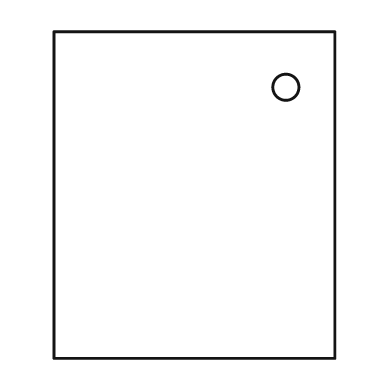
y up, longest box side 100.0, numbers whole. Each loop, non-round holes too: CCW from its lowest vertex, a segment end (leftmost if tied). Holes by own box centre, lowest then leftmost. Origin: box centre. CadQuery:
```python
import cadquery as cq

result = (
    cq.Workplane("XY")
    .moveTo(-43.0, -50.0)
    .lineTo(43.0, -50.0)
    .lineTo(43.0, 50.0)
    .lineTo(-43.0, 50.0)
    .close()
    .moveTo(28.0, 33.0)
    .circle(4.0)
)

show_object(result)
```